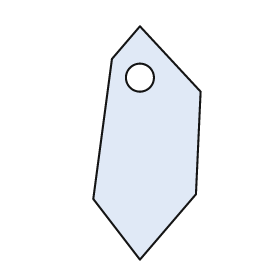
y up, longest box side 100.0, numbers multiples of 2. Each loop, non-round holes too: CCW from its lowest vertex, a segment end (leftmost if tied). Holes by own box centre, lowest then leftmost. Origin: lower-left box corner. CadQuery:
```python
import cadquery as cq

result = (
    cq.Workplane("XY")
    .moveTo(20.0, 0.0)
    .lineTo(44.0, 28.0)
    .lineTo(46.0, 72.0)
    .lineTo(20.0, 100.0)
    .lineTo(8.0, 86.0)
    .lineTo(0.0, 26.0)
    .close()
    .moveTo(20.0, 78.0)
    .circle(6.0)
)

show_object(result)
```